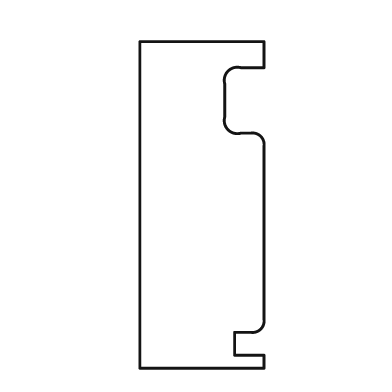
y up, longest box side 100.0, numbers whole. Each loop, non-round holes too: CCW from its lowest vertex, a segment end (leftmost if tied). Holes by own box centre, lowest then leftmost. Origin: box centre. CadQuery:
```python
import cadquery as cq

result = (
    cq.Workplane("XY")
    .moveTo(-19.0, -50.0)
    .lineTo(19.0, -50.0)
    .lineTo(19.0, -46.0)
    .lineTo(10.0, -46.0)
    .lineTo(10.0, -39.0)
    .lineTo(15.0, -39.0)
    .threePointArc((18.0, -38.0), (19.0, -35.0))
    .lineTo(19.0, 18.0)
    .threePointArc((18.0, 21.0), (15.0, 22.0))
    .lineTo(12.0, 22.0)
    .threePointArc((8.0, 23.0), (7.0, 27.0))
    .lineTo(7.0, 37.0)
    .threePointArc((8.0, 41.0), (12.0, 42.0))
    .lineTo(19.0, 42.0)
    .lineTo(19.0, 50.0)
    .lineTo(-19.0, 50.0)
    .close()
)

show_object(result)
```